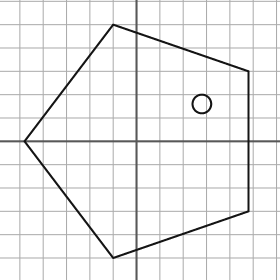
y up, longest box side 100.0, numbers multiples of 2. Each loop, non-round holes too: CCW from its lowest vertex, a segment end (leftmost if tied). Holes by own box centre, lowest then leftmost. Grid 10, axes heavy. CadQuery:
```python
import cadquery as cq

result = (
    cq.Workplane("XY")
    .moveTo(-10.0, -50.0)
    .lineTo(48.0, -30.0)
    .lineTo(48.0, 30.0)
    .lineTo(-10.0, 50.0)
    .lineTo(-48.0, 0.0)
    .close()
    .moveTo(28.0, 16.0)
    .circle(4.0)
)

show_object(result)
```